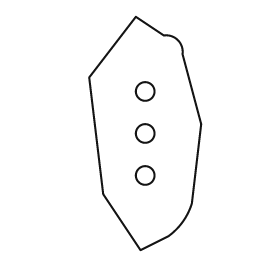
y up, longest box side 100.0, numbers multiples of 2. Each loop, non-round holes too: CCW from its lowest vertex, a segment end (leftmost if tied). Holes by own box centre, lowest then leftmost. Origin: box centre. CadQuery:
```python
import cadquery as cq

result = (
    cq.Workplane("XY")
    .moveTo(-2.0, -50.0)
    .lineTo(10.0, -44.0)
    .threePointArc((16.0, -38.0), (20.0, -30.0))
    .lineTo(24.0, 4.0)
    .lineTo(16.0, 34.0)
    .threePointArc((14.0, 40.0), (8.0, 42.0))
    .lineTo(-4.0, 50.0)
    .lineTo(-24.0, 24.0)
    .lineTo(-18.0, -26.0)
    .close()
    .moveTo(0.0, -18.0)
    .circle(4.0)
    .moveTo(0.0, 0.0)
    .circle(4.0)
    .moveTo(0.0, 18.0)
    .circle(4.0)
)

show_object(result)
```